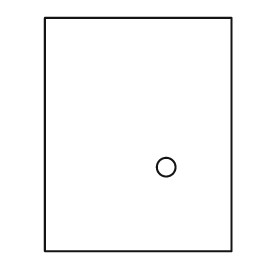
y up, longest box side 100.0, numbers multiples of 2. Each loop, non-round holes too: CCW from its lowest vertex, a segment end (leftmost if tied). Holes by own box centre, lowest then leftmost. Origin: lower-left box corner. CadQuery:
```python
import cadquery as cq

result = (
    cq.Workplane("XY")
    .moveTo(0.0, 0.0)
    .lineTo(80.0, 0.0)
    .lineTo(80.0, 100.0)
    .lineTo(0.0, 100.0)
    .close()
    .moveTo(52.0, 36.0)
    .circle(4.0)
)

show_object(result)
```